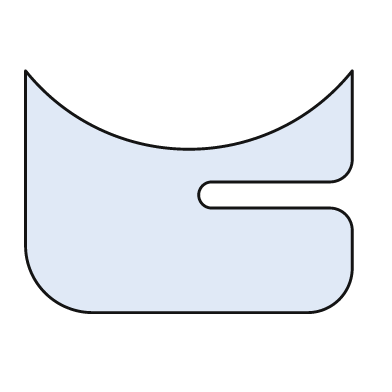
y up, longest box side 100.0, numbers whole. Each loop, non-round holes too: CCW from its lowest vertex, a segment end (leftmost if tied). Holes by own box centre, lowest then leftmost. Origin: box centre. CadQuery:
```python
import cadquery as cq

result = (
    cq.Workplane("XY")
    .moveTo(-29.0, -37.0)
    .lineTo(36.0, -37.0)
    .threePointArc((46.0, -33.0), (50.0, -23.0))
    .lineTo(50.0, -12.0)
    .threePointArc((48.0, -7.0), (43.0, -5.0))
    .lineTo(7.0, -5.0)
    .threePointArc((3.0, -1.0), (7.0, 3.0))
    .lineTo(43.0, 3.0)
    .threePointArc((48.0, 5.0), (50.0, 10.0))
    .lineTo(50.0, 37.0)
    .threePointArc((0.0, 13.0), (-50.0, 37.0))
    .lineTo(-50.0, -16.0)
    .threePointArc((-44.0, -31.0), (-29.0, -37.0))
    .close()
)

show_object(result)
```